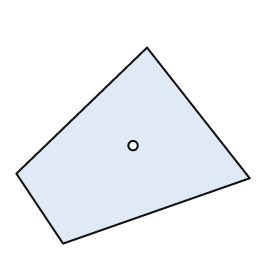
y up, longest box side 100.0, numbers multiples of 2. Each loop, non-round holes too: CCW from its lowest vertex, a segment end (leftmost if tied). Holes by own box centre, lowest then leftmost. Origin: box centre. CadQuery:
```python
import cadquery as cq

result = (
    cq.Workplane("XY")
    .moveTo(-30.0, -42.0)
    .lineTo(50.0, -14.0)
    .lineTo(6.0, 42.0)
    .lineTo(-50.0, -12.0)
    .close()
    .moveTo(0.0, 0.0)
    .circle(2.0)
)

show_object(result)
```